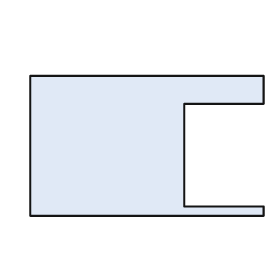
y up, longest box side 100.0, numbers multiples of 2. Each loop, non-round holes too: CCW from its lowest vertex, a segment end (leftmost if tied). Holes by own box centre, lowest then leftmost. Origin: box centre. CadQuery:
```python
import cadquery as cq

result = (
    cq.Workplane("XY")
    .moveTo(-50.0, -30.0)
    .lineTo(50.0, -30.0)
    .lineTo(50.0, -26.0)
    .lineTo(16.0, -26.0)
    .lineTo(16.0, 18.0)
    .lineTo(50.0, 18.0)
    .lineTo(50.0, 30.0)
    .lineTo(-50.0, 30.0)
    .close()
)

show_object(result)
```